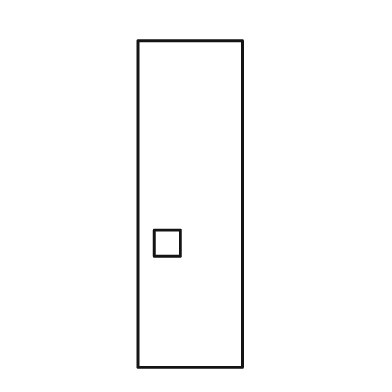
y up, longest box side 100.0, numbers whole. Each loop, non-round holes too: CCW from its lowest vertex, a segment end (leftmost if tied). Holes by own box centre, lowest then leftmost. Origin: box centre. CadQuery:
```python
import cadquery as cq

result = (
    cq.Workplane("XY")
    .moveTo(-16.0, -50.0)
    .lineTo(16.0, -50.0)
    .lineTo(16.0, 50.0)
    .lineTo(-16.0, 50.0)
    .close()
    .moveTo(-11.0, -16.0)
    .lineTo(-3.0, -16.0)
    .lineTo(-3.0, -8.0)
    .lineTo(-11.0, -8.0)
    .close()
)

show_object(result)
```